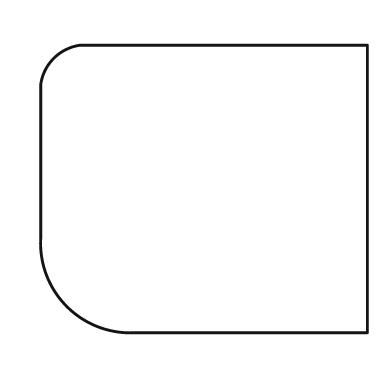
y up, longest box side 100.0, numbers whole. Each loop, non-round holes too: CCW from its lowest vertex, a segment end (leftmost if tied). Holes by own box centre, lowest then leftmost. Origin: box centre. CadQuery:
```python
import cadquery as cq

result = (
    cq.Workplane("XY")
    .moveTo(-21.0, -44.0)
    .lineTo(50.0, -44.0)
    .lineTo(50.0, 44.0)
    .lineTo(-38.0, 44.0)
    .threePointArc((-46.0, 40.0), (-50.0, 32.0))
    .lineTo(-50.0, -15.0)
    .threePointArc((-42.0, -36.0), (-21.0, -44.0))
    .close()
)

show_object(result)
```